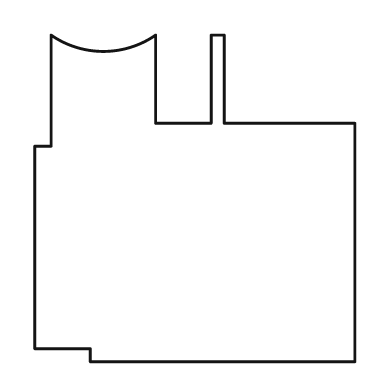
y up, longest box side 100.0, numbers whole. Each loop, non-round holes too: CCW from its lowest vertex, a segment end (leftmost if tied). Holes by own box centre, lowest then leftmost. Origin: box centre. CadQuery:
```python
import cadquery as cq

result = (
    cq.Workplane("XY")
    .moveTo(-32.0, -50.0)
    .lineTo(49.0, -50.0)
    .lineTo(49.0, 23.0)
    .lineTo(9.0, 23.0)
    .lineTo(9.0, 50.0)
    .lineTo(5.0, 50.0)
    .lineTo(5.0, 23.0)
    .lineTo(-12.0, 23.0)
    .lineTo(-12.0, 50.0)
    .threePointArc((-28.0, 45.0), (-44.0, 50.0))
    .lineTo(-44.0, 16.0)
    .lineTo(-49.0, 16.0)
    .lineTo(-49.0, -46.0)
    .lineTo(-32.0, -46.0)
    .close()
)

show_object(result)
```